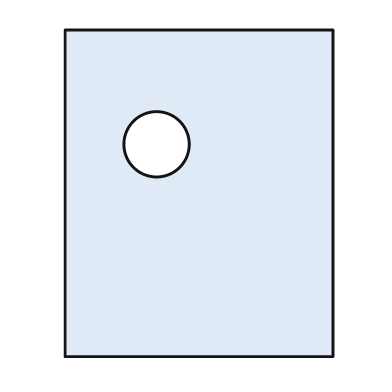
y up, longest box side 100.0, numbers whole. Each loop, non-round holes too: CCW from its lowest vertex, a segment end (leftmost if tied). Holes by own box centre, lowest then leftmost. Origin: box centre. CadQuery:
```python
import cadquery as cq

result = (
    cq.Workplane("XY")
    .moveTo(-41.0, -50.0)
    .lineTo(41.0, -50.0)
    .lineTo(41.0, 50.0)
    .lineTo(-41.0, 50.0)
    .close()
    .moveTo(-13.0, 15.0)
    .circle(10.0)
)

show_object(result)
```